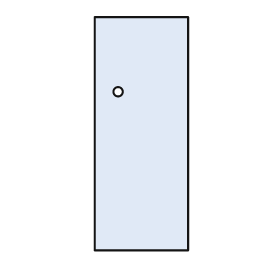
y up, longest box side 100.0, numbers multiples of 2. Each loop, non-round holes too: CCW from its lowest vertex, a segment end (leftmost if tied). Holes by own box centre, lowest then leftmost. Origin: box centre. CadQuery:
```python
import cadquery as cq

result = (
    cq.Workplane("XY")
    .moveTo(-20.0, -50.0)
    .lineTo(20.0, -50.0)
    .lineTo(20.0, 50.0)
    .lineTo(-20.0, 50.0)
    .close()
    .moveTo(-10.0, 18.0)
    .circle(2.0)
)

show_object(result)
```